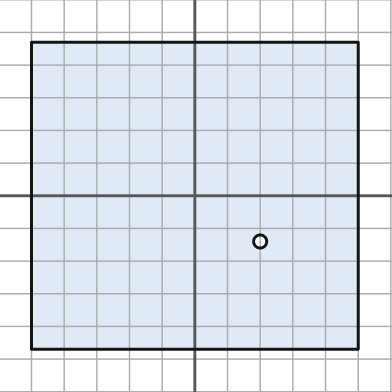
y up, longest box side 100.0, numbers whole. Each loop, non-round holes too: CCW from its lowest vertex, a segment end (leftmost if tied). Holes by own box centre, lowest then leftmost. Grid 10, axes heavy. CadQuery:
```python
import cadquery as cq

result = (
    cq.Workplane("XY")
    .moveTo(-50.0, -47.0)
    .lineTo(50.0, -47.0)
    .lineTo(50.0, 47.0)
    .lineTo(-50.0, 47.0)
    .close()
    .moveTo(20.0, -14.0)
    .circle(2.0)
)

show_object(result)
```